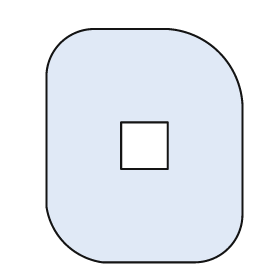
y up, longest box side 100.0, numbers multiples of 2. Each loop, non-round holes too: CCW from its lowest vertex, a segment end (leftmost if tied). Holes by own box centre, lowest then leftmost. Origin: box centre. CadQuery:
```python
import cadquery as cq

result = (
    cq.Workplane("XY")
    .moveTo(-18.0, -50.0)
    .lineTo(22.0, -50.0)
    .threePointArc((36.0, -44.0), (42.0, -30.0))
    .lineTo(42.0, 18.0)
    .threePointArc((32.0, 40.0), (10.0, 50.0))
    .lineTo(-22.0, 50.0)
    .threePointArc((-36.0, 44.0), (-42.0, 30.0))
    .lineTo(-42.0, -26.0)
    .threePointArc((-34.0, -42.0), (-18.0, -50.0))
    .close()
    .moveTo(-10.0, -10.0)
    .lineTo(10.0, -10.0)
    .lineTo(10.0, 10.0)
    .lineTo(-10.0, 10.0)
    .close()
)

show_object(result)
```